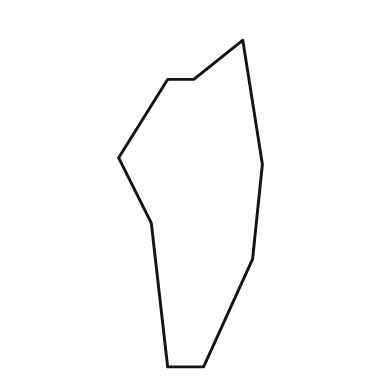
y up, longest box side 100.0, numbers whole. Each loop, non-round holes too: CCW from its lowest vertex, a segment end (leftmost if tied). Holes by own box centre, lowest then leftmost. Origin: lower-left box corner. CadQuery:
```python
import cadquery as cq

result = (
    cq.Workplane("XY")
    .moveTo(15.0, 0.0)
    .lineTo(26.0, 0.0)
    .lineTo(41.0, 33.0)
    .lineTo(44.0, 62.0)
    .lineTo(38.0, 100.0)
    .lineTo(23.0, 88.0)
    .lineTo(15.0, 88.0)
    .lineTo(0.0, 64.0)
    .lineTo(10.0, 44.0)
    .close()
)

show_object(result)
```